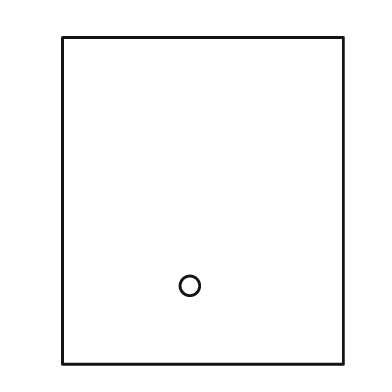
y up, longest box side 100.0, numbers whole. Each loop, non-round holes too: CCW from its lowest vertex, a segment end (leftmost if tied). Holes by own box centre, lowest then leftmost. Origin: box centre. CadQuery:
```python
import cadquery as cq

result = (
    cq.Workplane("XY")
    .moveTo(-43.0, -50.0)
    .lineTo(43.0, -50.0)
    .lineTo(43.0, 50.0)
    .lineTo(-43.0, 50.0)
    .close()
    .moveTo(-4.0, -26.0)
    .circle(3.0)
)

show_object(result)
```